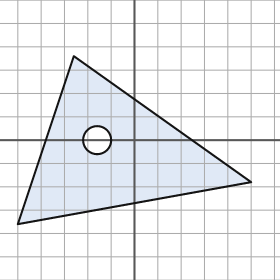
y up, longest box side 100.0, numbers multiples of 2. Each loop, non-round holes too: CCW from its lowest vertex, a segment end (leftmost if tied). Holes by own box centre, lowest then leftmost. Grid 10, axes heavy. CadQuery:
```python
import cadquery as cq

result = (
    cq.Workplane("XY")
    .moveTo(-50.0, -36.0)
    .lineTo(50.0, -18.0)
    .lineTo(-26.0, 36.0)
    .close()
    .moveTo(-16.0, 0.0)
    .circle(6.0)
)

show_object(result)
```